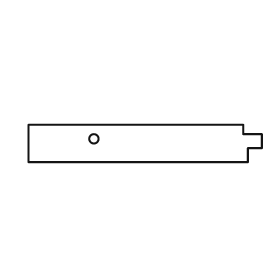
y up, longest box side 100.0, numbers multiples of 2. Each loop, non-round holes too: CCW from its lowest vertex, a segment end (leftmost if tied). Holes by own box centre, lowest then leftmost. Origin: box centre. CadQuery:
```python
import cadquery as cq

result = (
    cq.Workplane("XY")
    .moveTo(-50.0, -8.0)
    .lineTo(44.0, -8.0)
    .lineTo(44.0, -2.0)
    .lineTo(50.0, -2.0)
    .lineTo(50.0, 4.0)
    .lineTo(42.0, 4.0)
    .lineTo(42.0, 8.0)
    .lineTo(-50.0, 8.0)
    .close()
    .moveTo(-22.0, 2.0)
    .circle(2.0)
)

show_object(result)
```